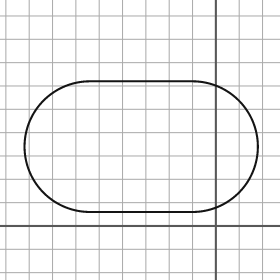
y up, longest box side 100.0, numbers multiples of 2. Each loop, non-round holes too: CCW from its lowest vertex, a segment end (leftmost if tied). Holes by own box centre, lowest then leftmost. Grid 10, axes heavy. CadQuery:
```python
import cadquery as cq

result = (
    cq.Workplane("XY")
    .moveTo(-54.0, 6.0)
    .lineTo(-10.0, 6.0)
    .threePointArc((18.0, 34.0), (-10.0, 62.0))
    .lineTo(-54.0, 62.0)
    .threePointArc((-82.0, 34.0), (-54.0, 6.0))
    .close()
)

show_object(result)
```